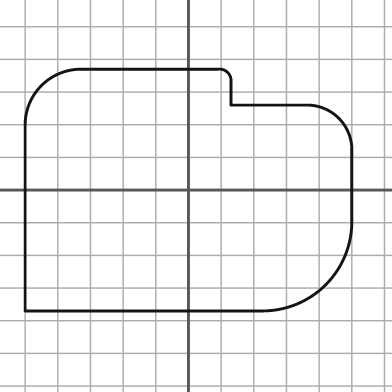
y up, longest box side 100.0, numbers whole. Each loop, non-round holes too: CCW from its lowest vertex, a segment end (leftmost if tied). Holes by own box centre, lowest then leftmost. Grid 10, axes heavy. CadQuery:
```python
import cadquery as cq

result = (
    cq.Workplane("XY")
    .moveTo(-50.0, -37.0)
    .lineTo(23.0, -37.0)
    .threePointArc((42.0, -29.0), (50.0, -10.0))
    .lineTo(50.0, 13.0)
    .threePointArc((46.0, 22.0), (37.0, 26.0))
    .lineTo(13.0, 26.0)
    .lineTo(13.0, 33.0)
    .threePointArc((12.0, 36.0), (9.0, 37.0))
    .lineTo(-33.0, 37.0)
    .threePointArc((-45.0, 32.0), (-50.0, 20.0))
    .close()
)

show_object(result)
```